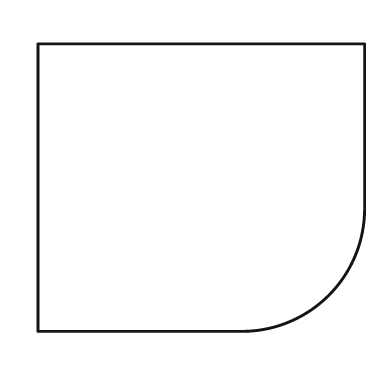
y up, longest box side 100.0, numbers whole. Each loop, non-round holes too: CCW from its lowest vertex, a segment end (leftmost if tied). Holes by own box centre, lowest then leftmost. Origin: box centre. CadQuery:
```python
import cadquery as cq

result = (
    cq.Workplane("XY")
    .moveTo(-50.0, -44.0)
    .lineTo(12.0, -44.0)
    .threePointArc((39.0, -33.0), (50.0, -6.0))
    .lineTo(50.0, 44.0)
    .lineTo(-50.0, 44.0)
    .close()
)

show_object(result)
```